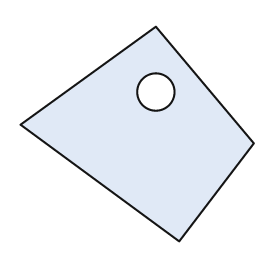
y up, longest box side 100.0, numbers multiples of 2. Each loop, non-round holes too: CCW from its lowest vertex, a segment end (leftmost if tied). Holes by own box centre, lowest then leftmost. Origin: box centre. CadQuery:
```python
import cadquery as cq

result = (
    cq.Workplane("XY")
    .moveTo(18.0, -46.0)
    .lineTo(50.0, -4.0)
    .lineTo(8.0, 46.0)
    .lineTo(-50.0, 4.0)
    .close()
    .moveTo(8.0, 18.0)
    .circle(8.0)
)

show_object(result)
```